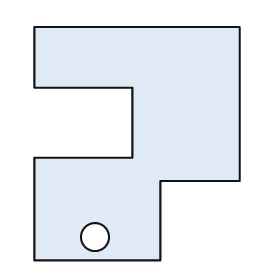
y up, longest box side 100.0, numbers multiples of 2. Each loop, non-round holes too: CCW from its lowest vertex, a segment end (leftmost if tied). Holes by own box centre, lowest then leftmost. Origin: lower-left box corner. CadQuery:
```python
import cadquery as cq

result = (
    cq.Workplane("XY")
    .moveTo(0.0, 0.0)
    .lineTo(54.0, 0.0)
    .lineTo(54.0, 34.0)
    .lineTo(88.0, 34.0)
    .lineTo(88.0, 100.0)
    .lineTo(0.0, 100.0)
    .lineTo(0.0, 74.0)
    .lineTo(42.0, 74.0)
    .lineTo(42.0, 44.0)
    .lineTo(0.0, 44.0)
    .close()
    .moveTo(26.0, 10.0)
    .circle(6.0)
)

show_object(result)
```